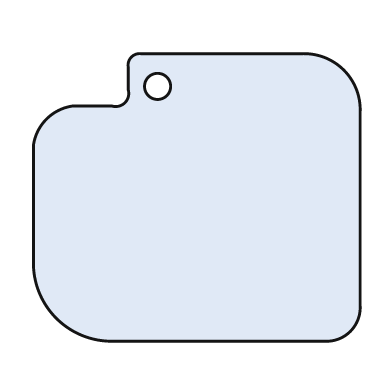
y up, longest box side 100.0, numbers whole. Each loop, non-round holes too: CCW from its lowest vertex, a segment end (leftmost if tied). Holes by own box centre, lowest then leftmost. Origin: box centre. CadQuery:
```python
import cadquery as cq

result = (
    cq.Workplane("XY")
    .moveTo(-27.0, -44.0)
    .lineTo(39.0, -44.0)
    .threePointArc((47.0, -41.0), (50.0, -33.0))
    .lineTo(50.0, 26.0)
    .threePointArc((45.0, 39.0), (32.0, 44.0))
    .lineTo(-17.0, 44.0)
    .threePointArc((-20.0, 43.0), (-21.0, 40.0))
    .lineTo(-21.0, 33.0)
    .threePointArc((-22.0, 29.0), (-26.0, 28.0))
    .lineTo(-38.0, 28.0)
    .threePointArc((-46.0, 24.0), (-50.0, 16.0))
    .lineTo(-50.0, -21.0)
    .threePointArc((-43.0, -37.0), (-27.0, -44.0))
    .close()
    .moveTo(-12.0, 34.0)
    .circle(4.0)
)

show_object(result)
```